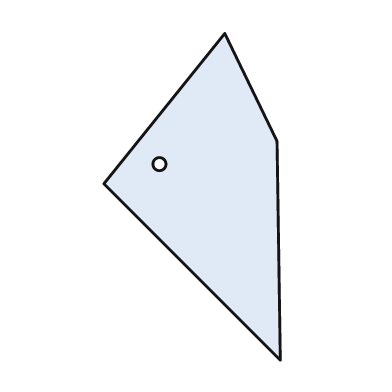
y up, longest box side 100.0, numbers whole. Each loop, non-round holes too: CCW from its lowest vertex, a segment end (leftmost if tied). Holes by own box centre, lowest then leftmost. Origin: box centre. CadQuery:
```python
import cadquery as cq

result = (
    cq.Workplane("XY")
    .moveTo(27.0, -50.0)
    .lineTo(26.0, 17.0)
    .lineTo(10.0, 50.0)
    .lineTo(-27.0, 4.0)
    .close()
    .moveTo(-10.0, 10.0)
    .circle(2.0)
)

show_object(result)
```